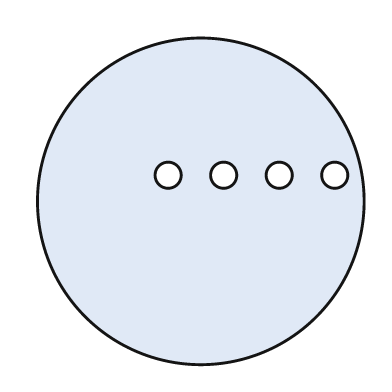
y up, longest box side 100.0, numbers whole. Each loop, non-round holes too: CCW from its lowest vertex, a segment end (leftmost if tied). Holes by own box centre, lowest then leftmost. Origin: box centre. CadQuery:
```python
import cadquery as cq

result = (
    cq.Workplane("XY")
    .moveTo(0.0, 0.0)
    .circle(50.0)
    .moveTo(-10.0, 8.0)
    .circle(4.0)
    .moveTo(7.0, 8.0)
    .circle(4.0)
    .moveTo(24.0, 8.0)
    .circle(4.0)
    .moveTo(41.0, 8.0)
    .circle(4.0)
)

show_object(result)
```